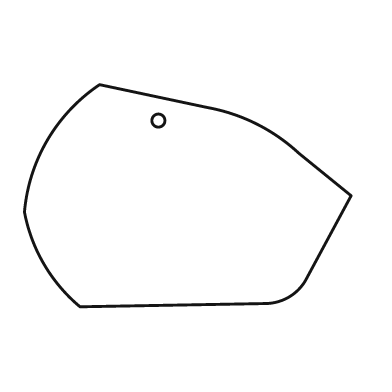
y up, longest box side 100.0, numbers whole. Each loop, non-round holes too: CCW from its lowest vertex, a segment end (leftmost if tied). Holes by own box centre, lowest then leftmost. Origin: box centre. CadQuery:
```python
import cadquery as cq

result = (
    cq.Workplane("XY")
    .moveTo(-33.0, -34.0)
    .lineTo(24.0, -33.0)
    .threePointArc((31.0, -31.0), (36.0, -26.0))
    .lineTo(50.0, 0.0)
    .lineTo(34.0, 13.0)
    .threePointArc((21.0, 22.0), (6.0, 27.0))
    .lineTo(-27.0, 34.0)
    .threePointArc((-43.0, 17.0), (-50.0, -5.0))
    .threePointArc((-44.0, -21.0), (-33.0, -34.0))
    .close()
    .moveTo(-9.0, 23.0)
    .circle(2.0)
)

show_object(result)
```